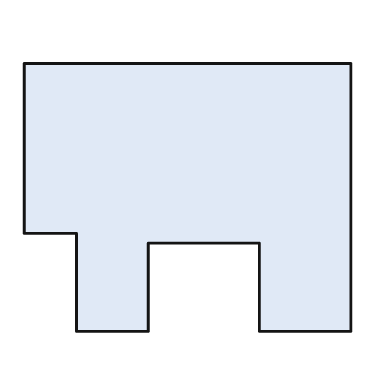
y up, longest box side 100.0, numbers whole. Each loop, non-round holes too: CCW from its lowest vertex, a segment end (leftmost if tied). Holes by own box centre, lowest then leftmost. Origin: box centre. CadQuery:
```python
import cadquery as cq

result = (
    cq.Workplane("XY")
    .moveTo(-34.0, -41.0)
    .lineTo(-12.0, -41.0)
    .lineTo(-12.0, -14.0)
    .lineTo(22.0, -14.0)
    .lineTo(22.0, -41.0)
    .lineTo(50.0, -41.0)
    .lineTo(50.0, 41.0)
    .lineTo(-50.0, 41.0)
    .lineTo(-50.0, -11.0)
    .lineTo(-34.0, -11.0)
    .close()
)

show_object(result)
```